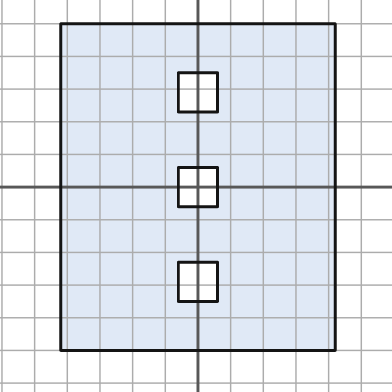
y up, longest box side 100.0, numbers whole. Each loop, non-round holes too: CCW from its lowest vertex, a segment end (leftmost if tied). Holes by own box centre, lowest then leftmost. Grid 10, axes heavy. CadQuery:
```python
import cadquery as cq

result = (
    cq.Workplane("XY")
    .moveTo(-42.0, -50.0)
    .lineTo(42.0, -50.0)
    .lineTo(42.0, 50.0)
    .lineTo(-42.0, 50.0)
    .close()
    .moveTo(-6.0, -35.0)
    .lineTo(6.0, -35.0)
    .lineTo(6.0, -23.0)
    .lineTo(-6.0, -23.0)
    .close()
    .moveTo(-6.0, -6.0)
    .lineTo(6.0, -6.0)
    .lineTo(6.0, 6.0)
    .lineTo(-6.0, 6.0)
    .close()
    .moveTo(-6.0, 23.0)
    .lineTo(6.0, 23.0)
    .lineTo(6.0, 35.0)
    .lineTo(-6.0, 35.0)
    .close()
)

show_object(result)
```